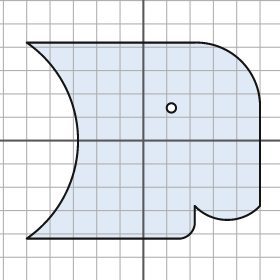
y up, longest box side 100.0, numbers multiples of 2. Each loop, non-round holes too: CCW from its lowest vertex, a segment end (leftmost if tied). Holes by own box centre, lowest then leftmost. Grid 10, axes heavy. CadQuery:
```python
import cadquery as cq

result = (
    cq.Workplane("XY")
    .moveTo(-50.0, -42.0)
    .lineTo(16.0, -42.0)
    .threePointArc((20.0, -40.0), (22.0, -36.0))
    .lineTo(22.0, -28.0)
    .threePointArc((36.0, -34.0), (50.0, -28.0))
    .lineTo(50.0, 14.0)
    .threePointArc((42.0, 34.0), (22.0, 42.0))
    .lineTo(-50.0, 42.0)
    .threePointArc((-28.0, 0.0), (-50.0, -42.0))
    .close()
    .moveTo(12.0, 14.0)
    .circle(2.0)
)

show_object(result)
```